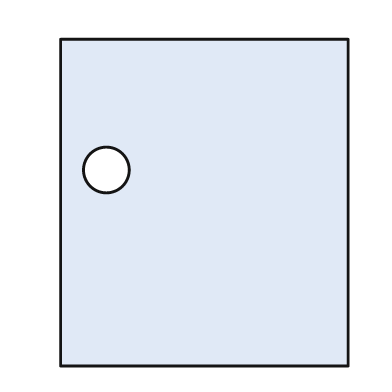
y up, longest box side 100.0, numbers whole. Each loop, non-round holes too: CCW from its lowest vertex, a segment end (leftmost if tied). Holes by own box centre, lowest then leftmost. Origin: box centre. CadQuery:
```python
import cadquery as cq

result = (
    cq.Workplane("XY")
    .moveTo(-44.0, -50.0)
    .lineTo(44.0, -50.0)
    .lineTo(44.0, 50.0)
    .lineTo(-44.0, 50.0)
    .close()
    .moveTo(-30.0, 10.0)
    .circle(7.0)
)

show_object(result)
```